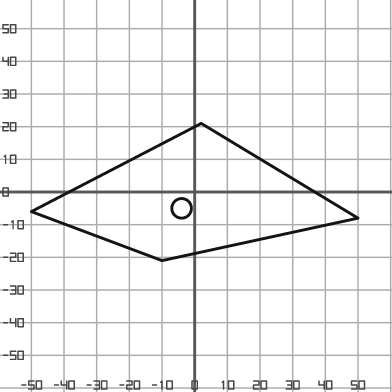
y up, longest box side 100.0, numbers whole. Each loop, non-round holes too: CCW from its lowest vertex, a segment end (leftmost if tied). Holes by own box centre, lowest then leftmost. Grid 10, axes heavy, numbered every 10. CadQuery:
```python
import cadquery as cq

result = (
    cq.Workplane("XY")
    .moveTo(-10.0, -21.0)
    .lineTo(50.0, -8.0)
    .lineTo(2.0, 21.0)
    .lineTo(-50.0, -6.0)
    .close()
    .moveTo(-4.0, -5.0)
    .circle(3.0)
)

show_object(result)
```